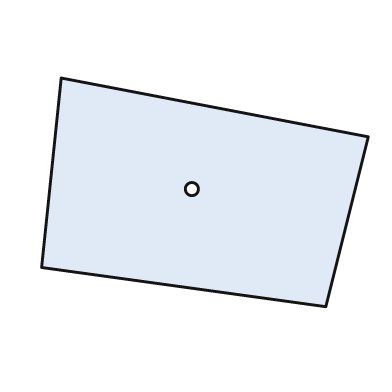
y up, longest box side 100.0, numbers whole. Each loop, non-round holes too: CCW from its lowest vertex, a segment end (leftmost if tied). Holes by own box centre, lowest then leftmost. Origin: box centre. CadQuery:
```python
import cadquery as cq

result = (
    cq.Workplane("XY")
    .moveTo(37.0, -35.0)
    .lineTo(50.0, 17.0)
    .lineTo(-44.0, 35.0)
    .lineTo(-50.0, -23.0)
    .close()
    .moveTo(-4.0, 1.0)
    .circle(2.0)
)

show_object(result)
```